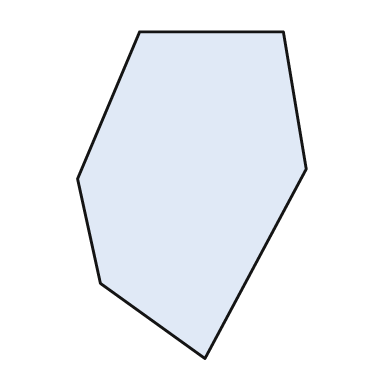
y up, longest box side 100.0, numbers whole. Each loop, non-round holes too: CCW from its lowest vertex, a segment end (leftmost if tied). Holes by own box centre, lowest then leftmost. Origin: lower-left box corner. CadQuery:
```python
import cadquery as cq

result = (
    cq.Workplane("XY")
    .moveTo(39.0, 0.0)
    .lineTo(70.0, 58.0)
    .lineTo(63.0, 100.0)
    .lineTo(19.0, 100.0)
    .lineTo(0.0, 55.0)
    .lineTo(7.0, 23.0)
    .close()
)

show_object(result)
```